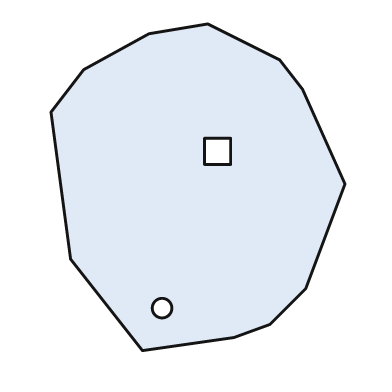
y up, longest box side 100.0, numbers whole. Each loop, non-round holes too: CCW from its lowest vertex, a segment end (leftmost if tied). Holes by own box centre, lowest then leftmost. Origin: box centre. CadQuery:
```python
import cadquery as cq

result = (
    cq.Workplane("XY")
    .moveTo(-17.0, -50.0)
    .lineTo(11.0, -46.0)
    .lineTo(22.0, -42.0)
    .lineTo(33.0, -31.0)
    .lineTo(45.0, 1.0)
    .lineTo(32.0, 30.0)
    .lineTo(25.0, 39.0)
    .lineTo(3.0, 50.0)
    .lineTo(-15.0, 47.0)
    .lineTo(-35.0, 36.0)
    .lineTo(-45.0, 23.0)
    .lineTo(-39.0, -22.0)
    .close()
    .moveTo(-11.0, -37.0)
    .circle(3.0)
    .moveTo(2.0, 7.0)
    .lineTo(10.0, 7.0)
    .lineTo(10.0, 15.0)
    .lineTo(2.0, 15.0)
    .close()
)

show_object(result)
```